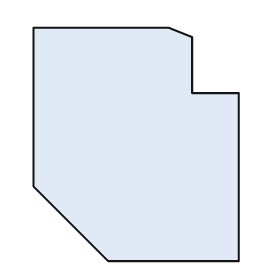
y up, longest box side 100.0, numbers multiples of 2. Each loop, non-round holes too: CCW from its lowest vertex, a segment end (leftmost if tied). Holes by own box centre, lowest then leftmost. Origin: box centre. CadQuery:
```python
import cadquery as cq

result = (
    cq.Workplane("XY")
    .moveTo(-12.0, -50.0)
    .lineTo(44.0, -50.0)
    .lineTo(44.0, 22.0)
    .lineTo(24.0, 22.0)
    .lineTo(24.0, 46.0)
    .lineTo(14.0, 50.0)
    .lineTo(-44.0, 50.0)
    .lineTo(-44.0, -18.0)
    .close()
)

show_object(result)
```